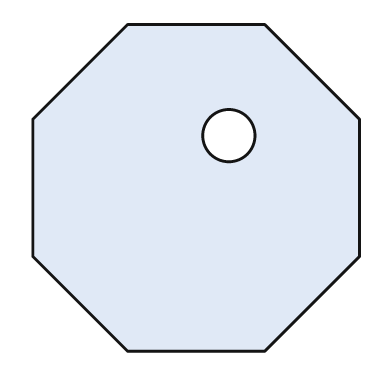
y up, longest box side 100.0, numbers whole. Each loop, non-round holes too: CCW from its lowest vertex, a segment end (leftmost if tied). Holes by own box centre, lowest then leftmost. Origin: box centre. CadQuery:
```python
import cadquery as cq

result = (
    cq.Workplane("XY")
    .moveTo(-21.0, -50.0)
    .lineTo(21.0, -50.0)
    .lineTo(50.0, -21.0)
    .lineTo(50.0, 21.0)
    .lineTo(21.0, 50.0)
    .lineTo(-21.0, 50.0)
    .lineTo(-50.0, 21.0)
    .lineTo(-50.0, -21.0)
    .close()
    .moveTo(10.0, 16.0)
    .circle(8.0)
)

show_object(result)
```